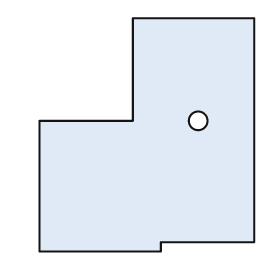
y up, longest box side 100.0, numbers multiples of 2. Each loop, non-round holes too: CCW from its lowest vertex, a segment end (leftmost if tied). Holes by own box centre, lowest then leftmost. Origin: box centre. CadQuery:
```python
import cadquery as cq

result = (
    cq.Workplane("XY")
    .moveTo(-46.0, -50.0)
    .lineTo(6.0, -50.0)
    .lineTo(6.0, -46.0)
    .lineTo(46.0, -46.0)
    .lineTo(46.0, 50.0)
    .lineTo(-6.0, 50.0)
    .lineTo(-6.0, 6.0)
    .lineTo(-46.0, 6.0)
    .close()
    .moveTo(22.0, 6.0)
    .circle(4.0)
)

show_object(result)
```